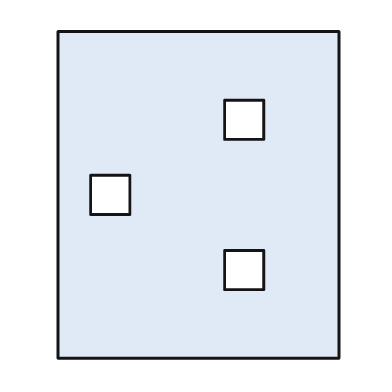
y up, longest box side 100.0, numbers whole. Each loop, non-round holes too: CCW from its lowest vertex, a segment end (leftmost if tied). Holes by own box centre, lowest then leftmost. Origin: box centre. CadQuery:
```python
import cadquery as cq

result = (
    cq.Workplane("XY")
    .moveTo(-43.0, -50.0)
    .lineTo(43.0, -50.0)
    .lineTo(43.0, 50.0)
    .lineTo(-43.0, 50.0)
    .close()
    .moveTo(8.0, -29.0)
    .lineTo(20.0, -29.0)
    .lineTo(20.0, -17.0)
    .lineTo(8.0, -17.0)
    .close()
    .moveTo(-33.0, -6.0)
    .lineTo(-21.0, -6.0)
    .lineTo(-21.0, 6.0)
    .lineTo(-33.0, 6.0)
    .close()
    .moveTo(8.0, 17.0)
    .lineTo(20.0, 17.0)
    .lineTo(20.0, 29.0)
    .lineTo(8.0, 29.0)
    .close()
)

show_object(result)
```